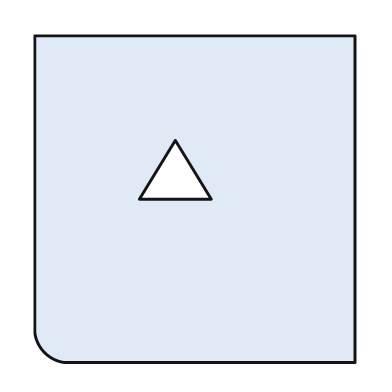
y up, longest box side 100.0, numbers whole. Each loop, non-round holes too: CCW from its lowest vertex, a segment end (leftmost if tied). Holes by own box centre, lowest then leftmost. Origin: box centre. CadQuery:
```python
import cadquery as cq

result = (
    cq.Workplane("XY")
    .moveTo(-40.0, -50.0)
    .lineTo(49.0, -50.0)
    .lineTo(49.0, 50.0)
    .lineTo(-49.0, 50.0)
    .lineTo(-49.0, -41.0)
    .threePointArc((-46.0, -47.0), (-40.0, -50.0))
    .close()
    .moveTo(-17.0, 0.0)
    .lineTo(5.0, 0.0)
    .lineTo(-6.0, 18.0)
    .close()
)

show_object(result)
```